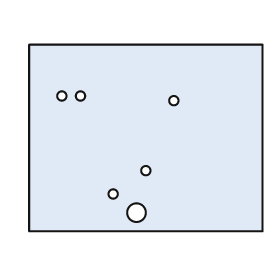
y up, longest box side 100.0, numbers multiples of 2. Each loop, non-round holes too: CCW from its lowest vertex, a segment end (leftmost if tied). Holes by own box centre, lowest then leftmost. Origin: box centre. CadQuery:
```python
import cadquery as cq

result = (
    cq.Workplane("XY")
    .moveTo(-50.0, -40.0)
    .lineTo(50.0, -40.0)
    .lineTo(50.0, 40.0)
    .lineTo(-50.0, 40.0)
    .close()
    .moveTo(-4.0, -32.0)
    .circle(4.0)
    .moveTo(-14.0, -24.0)
    .circle(2.0)
    .moveTo(0.0, -14.0)
    .circle(2.0)
    .moveTo(12.0, 16.0)
    .circle(2.0)
    .moveTo(-36.0, 18.0)
    .circle(2.0)
    .moveTo(-28.0, 18.0)
    .circle(2.0)
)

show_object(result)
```